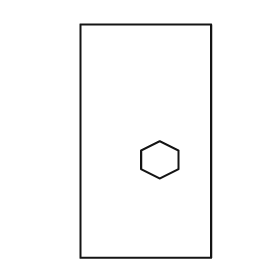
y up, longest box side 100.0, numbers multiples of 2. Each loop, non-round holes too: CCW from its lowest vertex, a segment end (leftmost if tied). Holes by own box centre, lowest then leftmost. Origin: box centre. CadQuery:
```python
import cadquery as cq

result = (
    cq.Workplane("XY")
    .moveTo(-28.0, -50.0)
    .lineTo(28.0, -50.0)
    .lineTo(28.0, 50.0)
    .lineTo(-28.0, 50.0)
    .close()
    .moveTo(6.0, -16.0)
    .lineTo(14.0, -12.0)
    .lineTo(14.0, -4.0)
    .lineTo(6.0, 0.0)
    .lineTo(-2.0, -4.0)
    .lineTo(-2.0, -12.0)
    .close()
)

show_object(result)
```